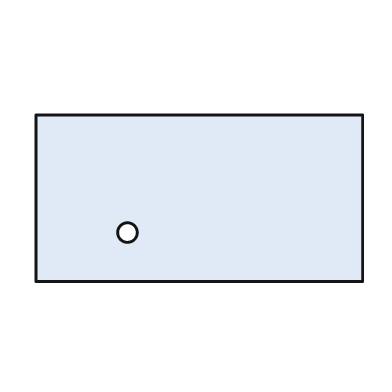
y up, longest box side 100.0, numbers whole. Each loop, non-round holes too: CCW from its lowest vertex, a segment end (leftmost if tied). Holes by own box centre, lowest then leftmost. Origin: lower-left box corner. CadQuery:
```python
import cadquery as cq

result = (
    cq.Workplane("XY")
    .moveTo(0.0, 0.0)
    .lineTo(100.0, 0.0)
    .lineTo(100.0, 51.0)
    .lineTo(0.0, 51.0)
    .close()
    .moveTo(28.0, 15.0)
    .circle(3.0)
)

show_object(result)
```